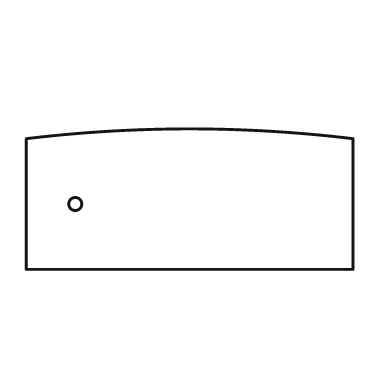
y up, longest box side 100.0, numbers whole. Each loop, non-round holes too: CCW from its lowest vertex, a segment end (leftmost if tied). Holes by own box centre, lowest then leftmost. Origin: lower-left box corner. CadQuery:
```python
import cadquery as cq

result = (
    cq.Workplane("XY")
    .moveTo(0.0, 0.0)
    .lineTo(100.0, 0.0)
    .lineTo(100.0, 40.0)
    .threePointArc((50.0, 43.0), (0.0, 40.0))
    .close()
    .moveTo(15.0, 20.0)
    .circle(2.0)
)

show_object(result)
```